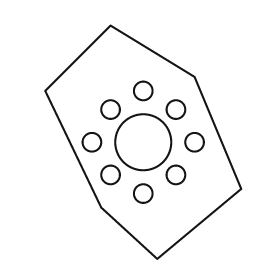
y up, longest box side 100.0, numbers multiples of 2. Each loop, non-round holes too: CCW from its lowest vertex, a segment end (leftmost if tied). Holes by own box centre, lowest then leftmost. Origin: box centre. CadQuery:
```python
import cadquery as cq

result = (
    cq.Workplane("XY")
    .moveTo(6.0, -50.0)
    .lineTo(42.0, -20.0)
    .lineTo(22.0, 28.0)
    .lineTo(-14.0, 50.0)
    .lineTo(-42.0, 22.0)
    .lineTo(-18.0, -28.0)
    .close()
    .moveTo(0.0, -22.0)
    .circle(4.0)
    .moveTo(-14.0, -14.0)
    .circle(4.0)
    .moveTo(14.0, -14.0)
    .circle(4.0)
    .moveTo(-22.0, 0.0)
    .circle(4.0)
    .moveTo(0.0, 0.0)
    .circle(12.0)
    .moveTo(22.0, 0.0)
    .circle(4.0)
    .moveTo(-14.0, 14.0)
    .circle(4.0)
    .moveTo(14.0, 14.0)
    .circle(4.0)
    .moveTo(0.0, 22.0)
    .circle(4.0)
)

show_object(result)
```